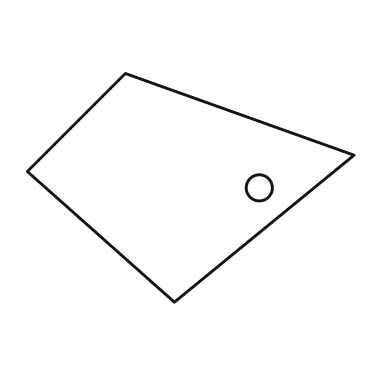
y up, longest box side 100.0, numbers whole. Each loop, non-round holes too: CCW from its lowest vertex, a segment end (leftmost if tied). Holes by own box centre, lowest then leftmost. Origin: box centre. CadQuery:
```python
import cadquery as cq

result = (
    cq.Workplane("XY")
    .moveTo(-5.0, -35.0)
    .lineTo(50.0, 10.0)
    .lineTo(-20.0, 35.0)
    .lineTo(-50.0, 5.0)
    .close()
    .moveTo(21.0, 0.0)
    .circle(4.0)
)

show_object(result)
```